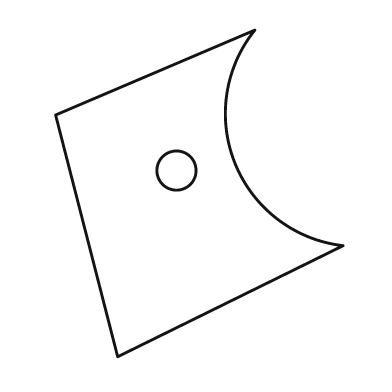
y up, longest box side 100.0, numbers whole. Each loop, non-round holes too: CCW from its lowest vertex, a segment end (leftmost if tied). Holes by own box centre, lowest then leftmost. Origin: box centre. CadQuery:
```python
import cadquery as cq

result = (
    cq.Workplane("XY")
    .moveTo(-25.0, -50.0)
    .lineTo(44.0, -16.0)
    .threePointArc((11.0, 9.0), (17.0, 50.0))
    .lineTo(-44.0, 24.0)
    .close()
    .moveTo(-7.0, 7.0)
    .circle(6.0)
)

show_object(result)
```